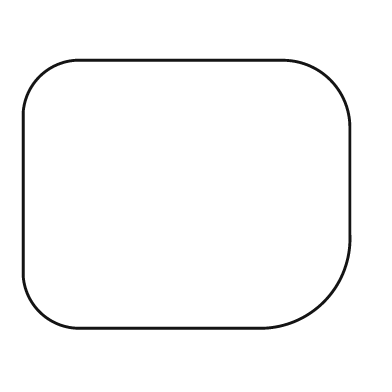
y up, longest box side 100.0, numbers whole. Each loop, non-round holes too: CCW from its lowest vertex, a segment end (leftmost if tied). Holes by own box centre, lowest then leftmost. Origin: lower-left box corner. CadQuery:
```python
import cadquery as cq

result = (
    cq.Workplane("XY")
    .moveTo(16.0, 0.0)
    .lineTo(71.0, 0.0)
    .threePointArc((92.0, 8.0), (100.0, 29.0))
    .lineTo(100.0, 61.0)
    .threePointArc((94.0, 76.0), (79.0, 82.0))
    .lineTo(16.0, 82.0)
    .threePointArc((5.0, 77.0), (0.0, 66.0))
    .lineTo(0.0, 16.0)
    .threePointArc((5.0, 5.0), (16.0, 0.0))
    .close()
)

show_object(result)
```